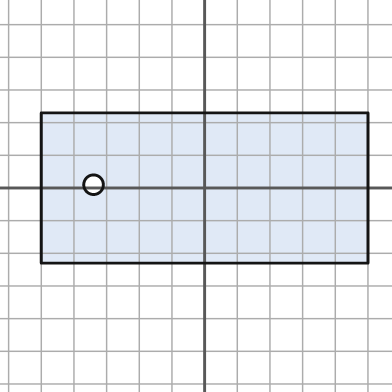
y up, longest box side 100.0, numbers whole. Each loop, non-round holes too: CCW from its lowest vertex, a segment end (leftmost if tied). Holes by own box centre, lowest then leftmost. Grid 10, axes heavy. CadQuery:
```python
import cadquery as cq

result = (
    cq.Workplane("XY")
    .moveTo(-50.0, -23.0)
    .lineTo(50.0, -23.0)
    .lineTo(50.0, 23.0)
    .lineTo(-50.0, 23.0)
    .close()
    .moveTo(-34.0, 1.0)
    .circle(3.0)
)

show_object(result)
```